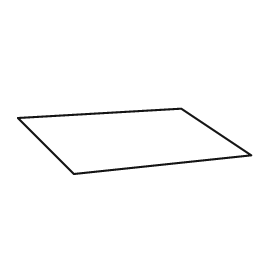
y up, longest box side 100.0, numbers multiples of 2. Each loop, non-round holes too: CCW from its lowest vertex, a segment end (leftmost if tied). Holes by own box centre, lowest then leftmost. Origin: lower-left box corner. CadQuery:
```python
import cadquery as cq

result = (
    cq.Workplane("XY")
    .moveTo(24.0, 0.0)
    .lineTo(100.0, 8.0)
    .lineTo(70.0, 28.0)
    .lineTo(0.0, 24.0)
    .close()
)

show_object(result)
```